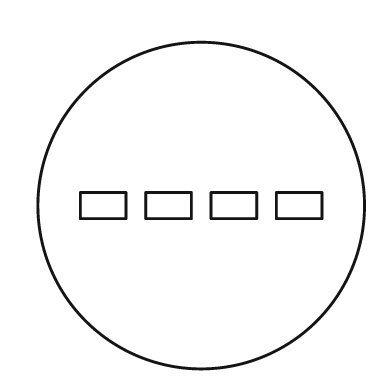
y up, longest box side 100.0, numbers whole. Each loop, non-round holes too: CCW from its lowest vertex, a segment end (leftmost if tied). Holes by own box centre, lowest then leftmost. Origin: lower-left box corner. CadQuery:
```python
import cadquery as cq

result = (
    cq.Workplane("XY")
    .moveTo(50.0, 50.0)
    .circle(50.0)
    .moveTo(13.0, 46.0)
    .lineTo(27.0, 46.0)
    .lineTo(27.0, 54.0)
    .lineTo(13.0, 54.0)
    .close()
    .moveTo(33.0, 46.0)
    .lineTo(47.0, 46.0)
    .lineTo(47.0, 54.0)
    .lineTo(33.0, 54.0)
    .close()
    .moveTo(53.0, 46.0)
    .lineTo(67.0, 46.0)
    .lineTo(67.0, 54.0)
    .lineTo(53.0, 54.0)
    .close()
    .moveTo(73.0, 46.0)
    .lineTo(87.0, 46.0)
    .lineTo(87.0, 54.0)
    .lineTo(73.0, 54.0)
    .close()
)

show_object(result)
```